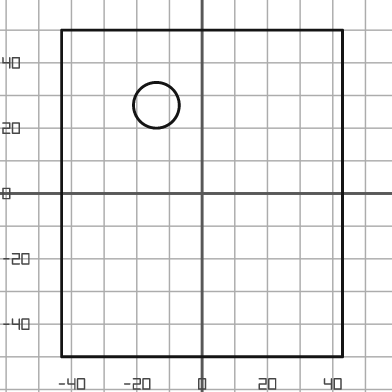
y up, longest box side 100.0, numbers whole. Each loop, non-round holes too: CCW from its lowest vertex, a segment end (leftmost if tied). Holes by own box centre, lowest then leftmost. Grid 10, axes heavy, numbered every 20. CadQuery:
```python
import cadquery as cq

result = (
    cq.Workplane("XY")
    .moveTo(-43.0, -50.0)
    .lineTo(43.0, -50.0)
    .lineTo(43.0, 50.0)
    .lineTo(-43.0, 50.0)
    .close()
    .moveTo(-14.0, 27.0)
    .circle(7.0)
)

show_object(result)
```